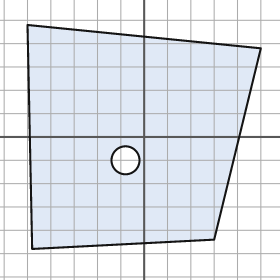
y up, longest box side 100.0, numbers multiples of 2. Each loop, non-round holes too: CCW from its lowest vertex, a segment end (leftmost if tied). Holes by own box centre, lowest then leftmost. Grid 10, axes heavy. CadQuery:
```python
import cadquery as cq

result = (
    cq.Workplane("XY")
    .moveTo(-48.0, -48.0)
    .lineTo(30.0, -44.0)
    .lineTo(50.0, 38.0)
    .lineTo(-50.0, 48.0)
    .close()
    .moveTo(-8.0, -10.0)
    .circle(6.0)
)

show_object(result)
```